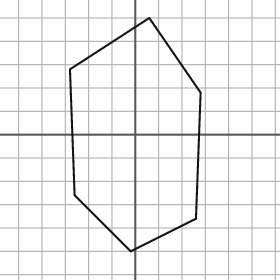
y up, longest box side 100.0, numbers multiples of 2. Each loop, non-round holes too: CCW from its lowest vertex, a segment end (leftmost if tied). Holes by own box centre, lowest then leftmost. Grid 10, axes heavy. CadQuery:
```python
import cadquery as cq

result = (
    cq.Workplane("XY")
    .moveTo(-2.0, -50.0)
    .lineTo(26.0, -36.0)
    .lineTo(28.0, 18.0)
    .lineTo(6.0, 50.0)
    .lineTo(-28.0, 28.0)
    .lineTo(-26.0, -26.0)
    .close()
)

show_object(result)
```